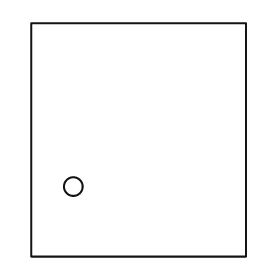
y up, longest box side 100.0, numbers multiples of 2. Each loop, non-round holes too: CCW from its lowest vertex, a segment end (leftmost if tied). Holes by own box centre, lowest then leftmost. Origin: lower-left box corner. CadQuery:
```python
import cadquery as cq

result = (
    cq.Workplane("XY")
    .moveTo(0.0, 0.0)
    .lineTo(92.0, 0.0)
    .lineTo(92.0, 100.0)
    .lineTo(0.0, 100.0)
    .close()
    .moveTo(18.0, 30.0)
    .circle(4.0)
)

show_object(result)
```